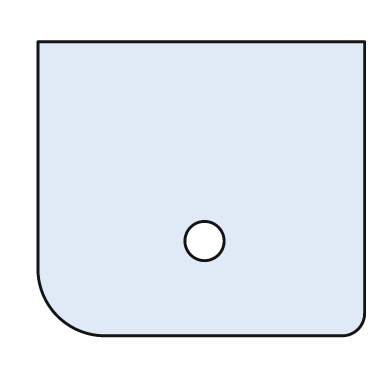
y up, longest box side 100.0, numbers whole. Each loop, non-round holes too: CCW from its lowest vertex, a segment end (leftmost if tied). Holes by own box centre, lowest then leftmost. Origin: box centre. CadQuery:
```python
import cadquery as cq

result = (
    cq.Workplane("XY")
    .moveTo(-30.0, -45.0)
    .lineTo(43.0, -45.0)
    .threePointArc((48.0, -43.0), (50.0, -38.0))
    .lineTo(50.0, 45.0)
    .lineTo(-50.0, 45.0)
    .lineTo(-50.0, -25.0)
    .threePointArc((-44.0, -39.0), (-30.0, -45.0))
    .close()
    .moveTo(1.0, -16.0)
    .circle(6.0)
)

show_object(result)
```